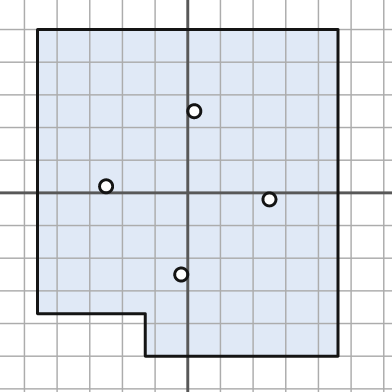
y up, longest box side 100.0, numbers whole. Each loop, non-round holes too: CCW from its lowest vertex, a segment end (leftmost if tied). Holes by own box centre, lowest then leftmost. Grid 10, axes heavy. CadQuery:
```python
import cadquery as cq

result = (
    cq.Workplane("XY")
    .moveTo(-13.0, -50.0)
    .lineTo(46.0, -50.0)
    .lineTo(46.0, 50.0)
    .lineTo(-46.0, 50.0)
    .lineTo(-46.0, -37.0)
    .lineTo(-13.0, -37.0)
    .close()
    .moveTo(-2.0, -25.0)
    .circle(2.0)
    .moveTo(25.0, -2.0)
    .circle(2.0)
    .moveTo(-25.0, 2.0)
    .circle(2.0)
    .moveTo(2.0, 25.0)
    .circle(2.0)
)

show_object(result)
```